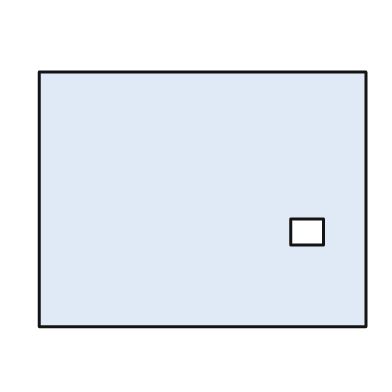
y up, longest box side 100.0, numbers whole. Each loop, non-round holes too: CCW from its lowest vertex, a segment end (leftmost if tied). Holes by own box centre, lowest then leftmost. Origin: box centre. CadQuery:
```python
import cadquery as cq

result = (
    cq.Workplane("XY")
    .moveTo(-50.0, -39.0)
    .lineTo(50.0, -39.0)
    .lineTo(50.0, 39.0)
    .lineTo(-50.0, 39.0)
    .close()
    .moveTo(27.0, -14.0)
    .lineTo(37.0, -14.0)
    .lineTo(37.0, -6.0)
    .lineTo(27.0, -6.0)
    .close()
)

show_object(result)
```